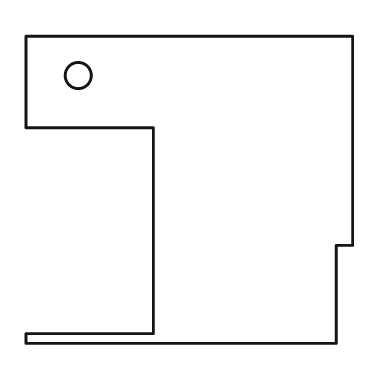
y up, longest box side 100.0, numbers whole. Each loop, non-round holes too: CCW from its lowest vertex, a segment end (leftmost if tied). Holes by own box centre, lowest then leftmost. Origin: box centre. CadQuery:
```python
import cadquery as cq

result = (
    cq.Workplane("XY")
    .moveTo(-50.0, -47.0)
    .lineTo(45.0, -47.0)
    .lineTo(45.0, -17.0)
    .lineTo(50.0, -17.0)
    .lineTo(50.0, 47.0)
    .lineTo(-50.0, 47.0)
    .lineTo(-50.0, 19.0)
    .lineTo(-11.0, 19.0)
    .lineTo(-11.0, -44.0)
    .lineTo(-50.0, -44.0)
    .close()
    .moveTo(-34.0, 35.0)
    .circle(4.0)
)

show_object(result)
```